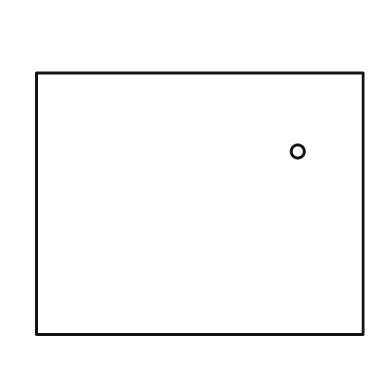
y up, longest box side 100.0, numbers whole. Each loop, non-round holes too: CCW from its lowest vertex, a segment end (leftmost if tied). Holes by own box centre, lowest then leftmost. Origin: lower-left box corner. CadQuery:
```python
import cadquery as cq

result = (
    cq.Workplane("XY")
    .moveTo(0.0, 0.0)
    .lineTo(100.0, 0.0)
    .lineTo(100.0, 80.0)
    .lineTo(0.0, 80.0)
    .close()
    .moveTo(80.0, 56.0)
    .circle(2.0)
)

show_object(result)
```